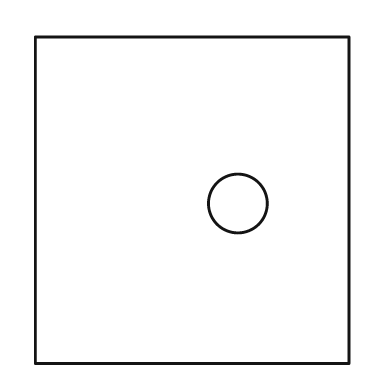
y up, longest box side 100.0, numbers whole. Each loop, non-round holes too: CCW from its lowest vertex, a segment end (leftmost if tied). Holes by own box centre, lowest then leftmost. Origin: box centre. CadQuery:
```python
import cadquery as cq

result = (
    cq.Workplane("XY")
    .moveTo(-48.0, -50.0)
    .lineTo(48.0, -50.0)
    .lineTo(48.0, 50.0)
    .lineTo(-48.0, 50.0)
    .close()
    .moveTo(14.0, -1.0)
    .circle(9.0)
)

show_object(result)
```